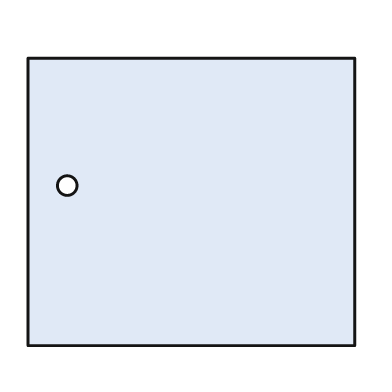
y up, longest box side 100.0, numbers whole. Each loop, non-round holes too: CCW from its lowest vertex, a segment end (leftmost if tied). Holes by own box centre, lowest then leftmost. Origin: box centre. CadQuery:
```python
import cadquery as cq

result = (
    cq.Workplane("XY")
    .moveTo(-50.0, -44.0)
    .lineTo(50.0, -44.0)
    .lineTo(50.0, 44.0)
    .lineTo(-50.0, 44.0)
    .close()
    .moveTo(-38.0, 5.0)
    .circle(3.0)
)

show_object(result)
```